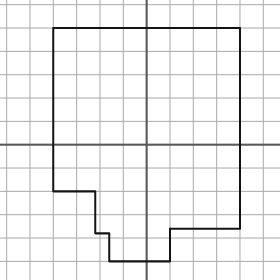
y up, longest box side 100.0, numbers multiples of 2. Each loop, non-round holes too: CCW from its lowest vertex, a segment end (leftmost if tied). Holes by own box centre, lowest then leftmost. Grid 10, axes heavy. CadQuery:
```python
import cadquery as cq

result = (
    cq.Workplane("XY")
    .moveTo(-16.0, -50.0)
    .lineTo(10.0, -50.0)
    .lineTo(10.0, -36.0)
    .lineTo(40.0, -36.0)
    .lineTo(40.0, 50.0)
    .lineTo(-40.0, 50.0)
    .lineTo(-40.0, -20.0)
    .lineTo(-22.0, -20.0)
    .lineTo(-22.0, -38.0)
    .lineTo(-16.0, -38.0)
    .close()
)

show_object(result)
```